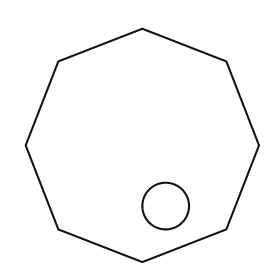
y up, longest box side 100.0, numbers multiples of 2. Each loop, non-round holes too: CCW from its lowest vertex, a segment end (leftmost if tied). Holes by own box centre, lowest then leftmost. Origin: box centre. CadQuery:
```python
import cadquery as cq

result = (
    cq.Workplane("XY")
    .moveTo(0.0, -50.0)
    .lineTo(36.0, -36.0)
    .lineTo(50.0, 0.0)
    .lineTo(36.0, 36.0)
    .lineTo(0.0, 50.0)
    .lineTo(-36.0, 36.0)
    .lineTo(-50.0, 0.0)
    .lineTo(-36.0, -36.0)
    .close()
    .moveTo(10.0, -26.0)
    .circle(10.0)
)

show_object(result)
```